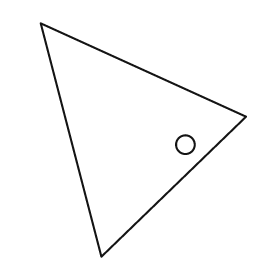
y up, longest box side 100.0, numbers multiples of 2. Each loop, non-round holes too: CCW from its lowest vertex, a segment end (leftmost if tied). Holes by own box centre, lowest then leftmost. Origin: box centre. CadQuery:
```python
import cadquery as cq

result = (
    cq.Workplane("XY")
    .moveTo(-18.0, -50.0)
    .lineTo(44.0, 10.0)
    .lineTo(-44.0, 50.0)
    .close()
    .moveTo(18.0, -2.0)
    .circle(4.0)
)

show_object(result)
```